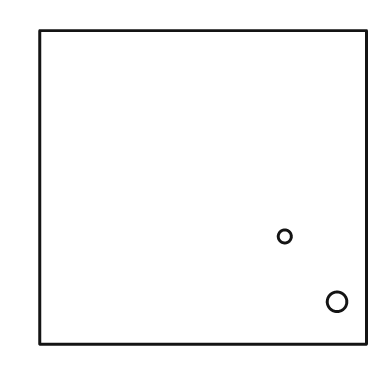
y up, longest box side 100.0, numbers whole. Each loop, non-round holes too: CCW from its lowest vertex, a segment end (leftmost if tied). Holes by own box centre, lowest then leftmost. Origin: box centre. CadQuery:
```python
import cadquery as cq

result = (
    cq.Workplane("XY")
    .moveTo(-50.0, -48.0)
    .lineTo(50.0, -48.0)
    .lineTo(50.0, 48.0)
    .lineTo(-50.0, 48.0)
    .close()
    .moveTo(41.0, -35.0)
    .circle(3.0)
    .moveTo(25.0, -15.0)
    .circle(2.0)
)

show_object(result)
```